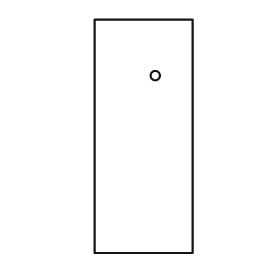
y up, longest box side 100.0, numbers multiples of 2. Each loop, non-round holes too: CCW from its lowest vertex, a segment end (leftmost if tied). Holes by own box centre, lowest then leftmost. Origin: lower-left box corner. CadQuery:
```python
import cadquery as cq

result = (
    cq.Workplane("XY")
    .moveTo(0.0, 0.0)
    .lineTo(42.0, 0.0)
    .lineTo(42.0, 100.0)
    .lineTo(0.0, 100.0)
    .close()
    .moveTo(26.0, 76.0)
    .circle(2.0)
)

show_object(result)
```